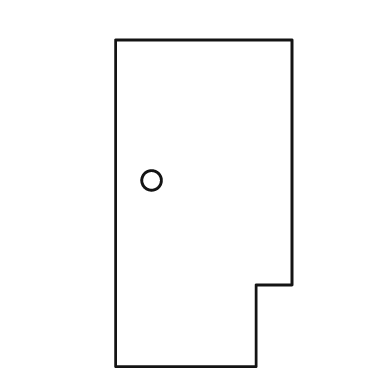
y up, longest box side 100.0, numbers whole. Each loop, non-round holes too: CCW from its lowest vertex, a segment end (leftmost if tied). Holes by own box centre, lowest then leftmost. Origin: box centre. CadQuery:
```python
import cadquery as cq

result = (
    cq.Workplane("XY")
    .moveTo(-27.0, -50.0)
    .lineTo(16.0, -50.0)
    .lineTo(16.0, -25.0)
    .lineTo(27.0, -25.0)
    .lineTo(27.0, 50.0)
    .lineTo(-27.0, 50.0)
    .close()
    .moveTo(-16.0, 7.0)
    .circle(3.0)
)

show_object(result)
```